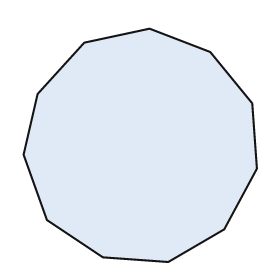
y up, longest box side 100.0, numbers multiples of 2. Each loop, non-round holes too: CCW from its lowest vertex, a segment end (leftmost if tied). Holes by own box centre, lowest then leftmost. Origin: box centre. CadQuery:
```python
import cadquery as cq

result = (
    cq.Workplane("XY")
    .moveTo(12.0, -50.0)
    .lineTo(36.0, -36.0)
    .lineTo(50.0, -10.0)
    .lineTo(48.0, 18.0)
    .lineTo(30.0, 40.0)
    .lineTo(4.0, 50.0)
    .lineTo(-24.0, 44.0)
    .lineTo(-44.0, 22.0)
    .lineTo(-50.0, -4.0)
    .lineTo(-40.0, -32.0)
    .lineTo(-16.0, -48.0)
    .close()
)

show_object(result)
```